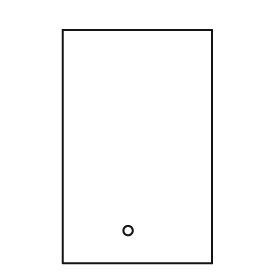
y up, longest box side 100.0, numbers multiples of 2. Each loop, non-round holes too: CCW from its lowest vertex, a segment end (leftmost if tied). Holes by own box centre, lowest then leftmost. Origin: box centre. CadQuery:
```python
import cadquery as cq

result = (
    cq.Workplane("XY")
    .moveTo(-32.0, -50.0)
    .lineTo(32.0, -50.0)
    .lineTo(32.0, 50.0)
    .lineTo(-32.0, 50.0)
    .close()
    .moveTo(-4.0, -36.0)
    .circle(2.0)
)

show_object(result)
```